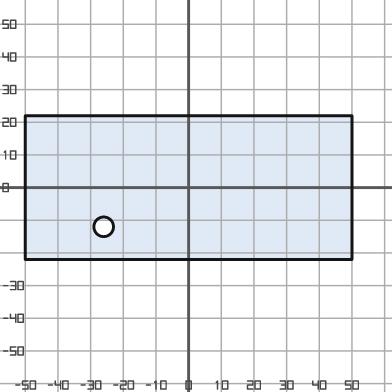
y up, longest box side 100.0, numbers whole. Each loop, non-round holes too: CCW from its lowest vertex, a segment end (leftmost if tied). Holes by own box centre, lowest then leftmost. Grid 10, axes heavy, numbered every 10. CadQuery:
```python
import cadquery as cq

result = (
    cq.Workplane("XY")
    .moveTo(-50.0, -22.0)
    .lineTo(50.0, -22.0)
    .lineTo(50.0, 22.0)
    .lineTo(-50.0, 22.0)
    .close()
    .moveTo(-26.0, -12.0)
    .circle(3.0)
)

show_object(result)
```